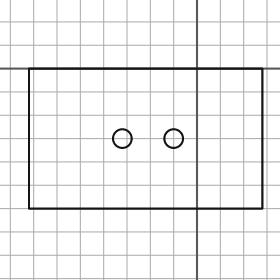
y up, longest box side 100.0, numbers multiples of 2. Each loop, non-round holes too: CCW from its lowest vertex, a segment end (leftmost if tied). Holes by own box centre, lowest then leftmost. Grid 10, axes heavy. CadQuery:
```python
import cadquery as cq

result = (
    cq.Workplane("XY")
    .moveTo(-72.0, -60.0)
    .lineTo(28.0, -60.0)
    .lineTo(28.0, 0.0)
    .lineTo(-72.0, 0.0)
    .close()
    .moveTo(-32.0, -30.0)
    .circle(4.0)
    .moveTo(-10.0, -30.0)
    .circle(4.0)
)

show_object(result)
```